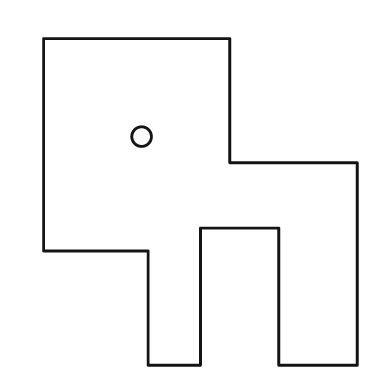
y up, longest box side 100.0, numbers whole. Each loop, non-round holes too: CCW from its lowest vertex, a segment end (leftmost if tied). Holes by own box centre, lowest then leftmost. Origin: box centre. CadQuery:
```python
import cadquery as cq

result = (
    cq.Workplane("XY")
    .moveTo(-16.0, -50.0)
    .lineTo(0.0, -50.0)
    .lineTo(0.0, -8.0)
    .lineTo(24.0, -8.0)
    .lineTo(24.0, -50.0)
    .lineTo(48.0, -50.0)
    .lineTo(48.0, 12.0)
    .lineTo(9.0, 12.0)
    .lineTo(9.0, 50.0)
    .lineTo(-48.0, 50.0)
    .lineTo(-48.0, -15.0)
    .lineTo(-16.0, -15.0)
    .close()
    .moveTo(-18.0, 20.0)
    .circle(3.0)
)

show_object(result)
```